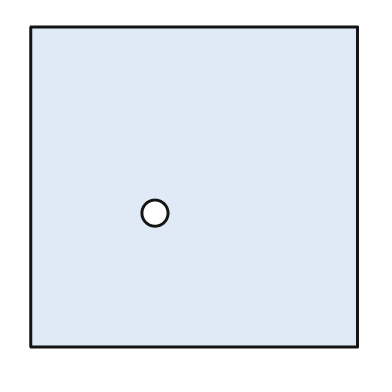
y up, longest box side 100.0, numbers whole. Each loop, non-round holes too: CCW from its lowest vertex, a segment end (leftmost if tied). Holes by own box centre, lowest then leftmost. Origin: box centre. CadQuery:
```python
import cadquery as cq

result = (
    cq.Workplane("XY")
    .moveTo(-50.0, -49.0)
    .lineTo(50.0, -49.0)
    .lineTo(50.0, 49.0)
    .lineTo(-50.0, 49.0)
    .close()
    .moveTo(-12.0, -8.0)
    .circle(4.0)
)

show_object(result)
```